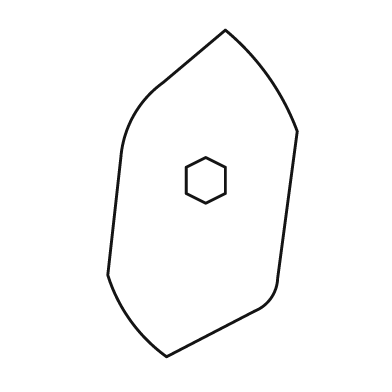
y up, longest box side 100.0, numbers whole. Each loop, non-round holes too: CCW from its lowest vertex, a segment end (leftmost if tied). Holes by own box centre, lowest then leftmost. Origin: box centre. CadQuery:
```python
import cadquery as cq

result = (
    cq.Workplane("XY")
    .moveTo(-11.0, -50.0)
    .lineTo(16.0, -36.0)
    .threePointArc((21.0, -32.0), (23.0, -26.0))
    .lineTo(29.0, 19.0)
    .threePointArc((20.0, 36.0), (7.0, 50.0))
    .lineTo(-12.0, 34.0)
    .threePointArc((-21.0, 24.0), (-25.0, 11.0))
    .lineTo(-29.0, -25.0)
    .threePointArc((-22.0, -39.0), (-11.0, -50.0))
    .close()
    .moveTo(1.0, -3.0)
    .lineTo(7.0, 0.0)
    .lineTo(7.0, 8.0)
    .lineTo(1.0, 11.0)
    .lineTo(-5.0, 8.0)
    .lineTo(-5.0, 0.0)
    .close()
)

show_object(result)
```